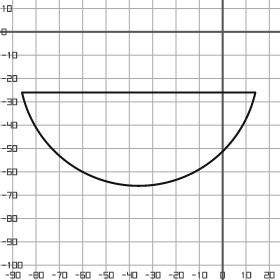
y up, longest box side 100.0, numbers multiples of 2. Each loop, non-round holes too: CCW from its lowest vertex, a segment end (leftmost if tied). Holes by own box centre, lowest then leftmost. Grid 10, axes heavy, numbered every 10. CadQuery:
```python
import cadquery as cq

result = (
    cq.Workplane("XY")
    .moveTo(-86.0, -26.0)
    .threePointArc((-36.0, -66.0), (14.0, -26.0))
    .close()
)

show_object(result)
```